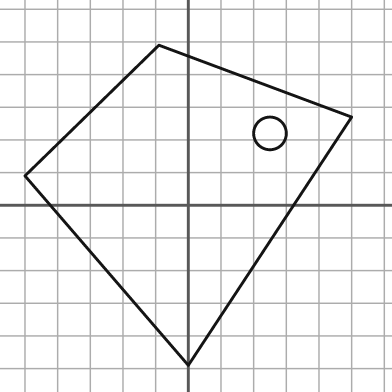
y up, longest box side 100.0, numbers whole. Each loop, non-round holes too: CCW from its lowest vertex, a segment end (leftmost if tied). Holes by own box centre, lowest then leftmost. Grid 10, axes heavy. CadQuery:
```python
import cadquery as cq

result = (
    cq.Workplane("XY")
    .moveTo(0.0, -49.0)
    .lineTo(50.0, 27.0)
    .lineTo(-9.0, 49.0)
    .lineTo(-50.0, 9.0)
    .close()
    .moveTo(25.0, 22.0)
    .circle(5.0)
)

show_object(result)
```